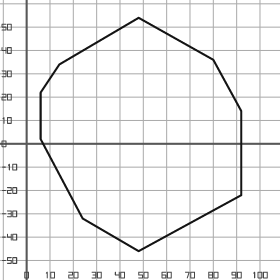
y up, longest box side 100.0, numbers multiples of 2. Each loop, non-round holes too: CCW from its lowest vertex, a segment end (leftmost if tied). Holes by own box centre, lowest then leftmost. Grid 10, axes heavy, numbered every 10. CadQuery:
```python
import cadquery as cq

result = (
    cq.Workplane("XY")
    .moveTo(48.0, -46.0)
    .lineTo(92.0, -22.0)
    .lineTo(92.0, 14.0)
    .lineTo(80.0, 36.0)
    .lineTo(48.0, 54.0)
    .lineTo(14.0, 34.0)
    .lineTo(6.0, 22.0)
    .lineTo(6.0, 2.0)
    .lineTo(24.0, -32.0)
    .close()
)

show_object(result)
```